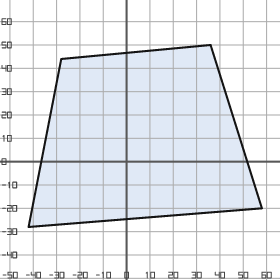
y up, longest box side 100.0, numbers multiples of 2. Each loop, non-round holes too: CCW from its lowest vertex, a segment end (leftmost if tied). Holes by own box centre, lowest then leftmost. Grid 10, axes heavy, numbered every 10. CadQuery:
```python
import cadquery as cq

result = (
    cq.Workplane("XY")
    .moveTo(-42.0, -28.0)
    .lineTo(58.0, -20.0)
    .lineTo(36.0, 50.0)
    .lineTo(-28.0, 44.0)
    .close()
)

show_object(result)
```